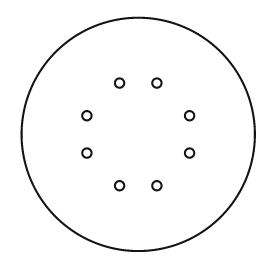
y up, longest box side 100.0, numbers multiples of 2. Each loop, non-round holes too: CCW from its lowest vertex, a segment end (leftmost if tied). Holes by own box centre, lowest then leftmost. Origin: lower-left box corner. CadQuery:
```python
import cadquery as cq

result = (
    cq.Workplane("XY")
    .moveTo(50.0, 50.0)
    .circle(50.0)
    .moveTo(42.0, 28.0)
    .circle(2.0)
    .moveTo(58.0, 28.0)
    .circle(2.0)
    .moveTo(28.0, 42.0)
    .circle(2.0)
    .moveTo(72.0, 42.0)
    .circle(2.0)
    .moveTo(28.0, 58.0)
    .circle(2.0)
    .moveTo(72.0, 58.0)
    .circle(2.0)
    .moveTo(42.0, 72.0)
    .circle(2.0)
    .moveTo(58.0, 72.0)
    .circle(2.0)
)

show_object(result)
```